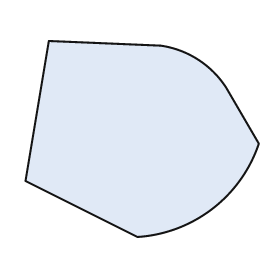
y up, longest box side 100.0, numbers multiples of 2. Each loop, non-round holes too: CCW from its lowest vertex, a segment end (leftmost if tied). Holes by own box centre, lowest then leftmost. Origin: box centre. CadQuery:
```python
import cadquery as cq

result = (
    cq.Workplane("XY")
    .moveTo(-2.0, -42.0)
    .threePointArc((30.0, -30.0), (50.0, -2.0))
    .lineTo(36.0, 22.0)
    .threePointArc((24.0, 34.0), (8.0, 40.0))
    .lineTo(-40.0, 42.0)
    .lineTo(-50.0, -18.0)
    .close()
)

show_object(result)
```